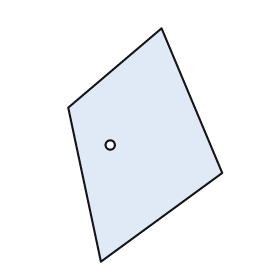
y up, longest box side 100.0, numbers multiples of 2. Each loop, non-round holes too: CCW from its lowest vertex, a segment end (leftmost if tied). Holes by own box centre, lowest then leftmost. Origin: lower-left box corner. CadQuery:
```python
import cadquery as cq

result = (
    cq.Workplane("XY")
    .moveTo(14.0, 0.0)
    .lineTo(66.0, 38.0)
    .lineTo(40.0, 100.0)
    .lineTo(0.0, 66.0)
    .close()
    .moveTo(18.0, 50.0)
    .circle(2.0)
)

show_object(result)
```